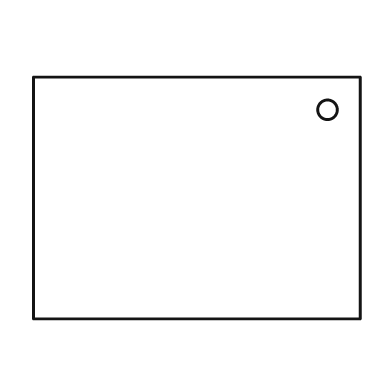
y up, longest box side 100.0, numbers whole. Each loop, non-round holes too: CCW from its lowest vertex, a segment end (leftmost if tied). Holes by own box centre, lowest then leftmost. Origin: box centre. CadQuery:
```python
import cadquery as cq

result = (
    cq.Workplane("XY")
    .moveTo(-50.0, -37.0)
    .lineTo(50.0, -37.0)
    .lineTo(50.0, 37.0)
    .lineTo(-50.0, 37.0)
    .close()
    .moveTo(40.0, 27.0)
    .circle(3.0)
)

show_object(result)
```